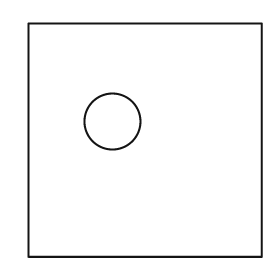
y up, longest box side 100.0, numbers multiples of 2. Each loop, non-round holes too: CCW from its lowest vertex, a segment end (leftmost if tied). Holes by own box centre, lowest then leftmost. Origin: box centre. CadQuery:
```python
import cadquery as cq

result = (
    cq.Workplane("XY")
    .moveTo(-50.0, -50.0)
    .lineTo(50.0, -50.0)
    .lineTo(50.0, 50.0)
    .lineTo(-50.0, 50.0)
    .close()
    .moveTo(-14.0, 8.0)
    .circle(12.0)
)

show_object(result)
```